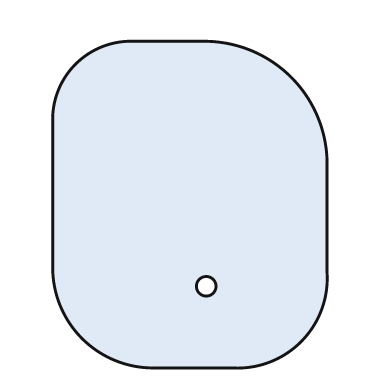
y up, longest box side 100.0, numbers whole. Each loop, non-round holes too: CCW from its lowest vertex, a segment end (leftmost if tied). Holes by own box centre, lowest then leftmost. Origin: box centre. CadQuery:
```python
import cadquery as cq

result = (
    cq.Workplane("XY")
    .moveTo(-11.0, -50.0)
    .lineTo(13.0, -50.0)
    .threePointArc((34.0, -42.0), (42.0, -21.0))
    .lineTo(42.0, 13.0)
    .threePointArc((31.0, 39.0), (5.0, 50.0))
    .lineTo(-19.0, 50.0)
    .threePointArc((-35.0, 43.0), (-42.0, 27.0))
    .lineTo(-42.0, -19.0)
    .threePointArc((-33.0, -41.0), (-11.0, -50.0))
    .close()
    .moveTo(5.0, -25.0)
    .circle(3.0)
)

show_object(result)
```